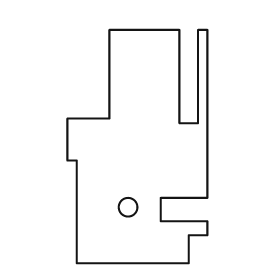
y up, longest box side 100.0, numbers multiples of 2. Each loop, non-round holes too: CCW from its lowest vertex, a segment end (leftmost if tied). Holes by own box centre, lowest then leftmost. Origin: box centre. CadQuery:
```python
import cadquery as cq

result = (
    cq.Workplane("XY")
    .moveTo(-26.0, -50.0)
    .lineTo(22.0, -50.0)
    .lineTo(22.0, -38.0)
    .lineTo(30.0, -38.0)
    .lineTo(30.0, -32.0)
    .lineTo(10.0, -32.0)
    .lineTo(10.0, -22.0)
    .lineTo(30.0, -22.0)
    .lineTo(30.0, 50.0)
    .lineTo(26.0, 50.0)
    .lineTo(26.0, 10.0)
    .lineTo(18.0, 10.0)
    .lineTo(18.0, 50.0)
    .lineTo(-12.0, 50.0)
    .lineTo(-12.0, 12.0)
    .lineTo(-30.0, 12.0)
    .lineTo(-30.0, -6.0)
    .lineTo(-26.0, -6.0)
    .close()
    .moveTo(-4.0, -26.0)
    .circle(4.0)
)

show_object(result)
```